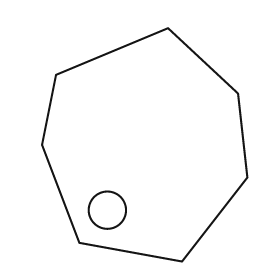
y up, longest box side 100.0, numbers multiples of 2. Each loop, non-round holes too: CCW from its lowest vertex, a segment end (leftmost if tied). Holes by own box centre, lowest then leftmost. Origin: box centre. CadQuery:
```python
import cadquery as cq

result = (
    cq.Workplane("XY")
    .moveTo(16.0, -50.0)
    .lineTo(44.0, -14.0)
    .lineTo(40.0, 22.0)
    .lineTo(10.0, 50.0)
    .lineTo(-38.0, 30.0)
    .lineTo(-44.0, 0.0)
    .lineTo(-28.0, -42.0)
    .close()
    .moveTo(-16.0, -28.0)
    .circle(8.0)
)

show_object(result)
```